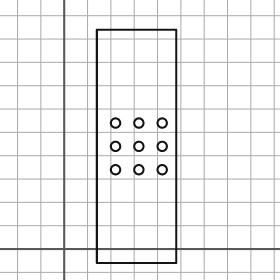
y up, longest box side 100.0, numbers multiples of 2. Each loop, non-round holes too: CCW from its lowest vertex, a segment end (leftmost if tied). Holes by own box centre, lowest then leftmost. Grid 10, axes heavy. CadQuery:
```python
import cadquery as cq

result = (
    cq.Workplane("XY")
    .moveTo(14.0, -6.0)
    .lineTo(48.0, -6.0)
    .lineTo(48.0, 94.0)
    .lineTo(14.0, 94.0)
    .close()
    .moveTo(22.0, 34.0)
    .circle(2.0)
    .moveTo(32.0, 34.0)
    .circle(2.0)
    .moveTo(42.0, 34.0)
    .circle(2.0)
    .moveTo(22.0, 44.0)
    .circle(2.0)
    .moveTo(32.0, 44.0)
    .circle(2.0)
    .moveTo(42.0, 44.0)
    .circle(2.0)
    .moveTo(22.0, 54.0)
    .circle(2.0)
    .moveTo(32.0, 54.0)
    .circle(2.0)
    .moveTo(42.0, 54.0)
    .circle(2.0)
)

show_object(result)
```